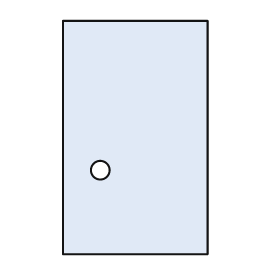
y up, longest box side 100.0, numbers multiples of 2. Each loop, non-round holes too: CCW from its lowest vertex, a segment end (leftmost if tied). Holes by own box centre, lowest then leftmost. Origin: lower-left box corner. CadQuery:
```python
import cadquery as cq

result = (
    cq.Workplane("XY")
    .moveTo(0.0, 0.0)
    .lineTo(62.0, 0.0)
    .lineTo(62.0, 100.0)
    .lineTo(0.0, 100.0)
    .close()
    .moveTo(16.0, 36.0)
    .circle(4.0)
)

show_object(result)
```